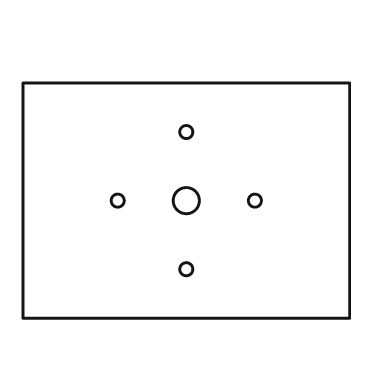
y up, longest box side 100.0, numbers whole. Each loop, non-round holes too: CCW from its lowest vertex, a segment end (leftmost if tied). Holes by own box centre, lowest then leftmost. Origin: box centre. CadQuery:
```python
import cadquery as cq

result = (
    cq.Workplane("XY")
    .moveTo(-50.0, -36.0)
    .lineTo(50.0, -36.0)
    .lineTo(50.0, 36.0)
    .lineTo(-50.0, 36.0)
    .close()
    .moveTo(0.0, -21.0)
    .circle(2.0)
    .moveTo(-21.0, 0.0)
    .circle(2.0)
    .moveTo(0.0, 0.0)
    .circle(4.0)
    .moveTo(21.0, 0.0)
    .circle(2.0)
    .moveTo(0.0, 21.0)
    .circle(2.0)
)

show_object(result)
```